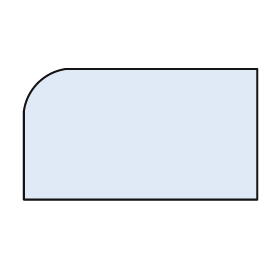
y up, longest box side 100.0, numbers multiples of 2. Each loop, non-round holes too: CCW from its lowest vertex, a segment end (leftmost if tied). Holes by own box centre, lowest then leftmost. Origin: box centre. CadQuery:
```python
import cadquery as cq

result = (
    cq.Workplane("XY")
    .moveTo(-50.0, -28.0)
    .lineTo(50.0, -28.0)
    .lineTo(50.0, 28.0)
    .lineTo(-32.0, 28.0)
    .threePointArc((-44.0, 22.0), (-50.0, 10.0))
    .close()
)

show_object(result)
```